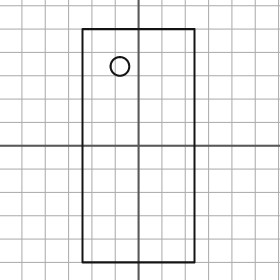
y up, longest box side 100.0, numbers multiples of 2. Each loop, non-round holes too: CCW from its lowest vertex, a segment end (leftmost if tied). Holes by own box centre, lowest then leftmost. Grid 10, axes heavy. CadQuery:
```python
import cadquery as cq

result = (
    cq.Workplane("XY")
    .moveTo(-24.0, -50.0)
    .lineTo(24.0, -50.0)
    .lineTo(24.0, 50.0)
    .lineTo(-24.0, 50.0)
    .close()
    .moveTo(-8.0, 34.0)
    .circle(4.0)
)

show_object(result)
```